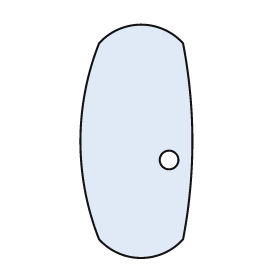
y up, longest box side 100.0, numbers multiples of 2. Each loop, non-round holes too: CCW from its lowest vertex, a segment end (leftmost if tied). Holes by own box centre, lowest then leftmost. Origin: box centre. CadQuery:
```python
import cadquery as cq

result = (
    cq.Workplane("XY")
    .moveTo(-16.0, -42.0)
    .threePointArc((2.0, -50.0), (20.0, -42.0))
    .threePointArc((24.0, 0.0), (20.0, 42.0))
    .threePointArc((2.0, 50.0), (-16.0, 42.0))
    .threePointArc((-24.0, 0.0), (-16.0, -42.0))
    .close()
    .moveTo(14.0, -8.0)
    .circle(4.0)
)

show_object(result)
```